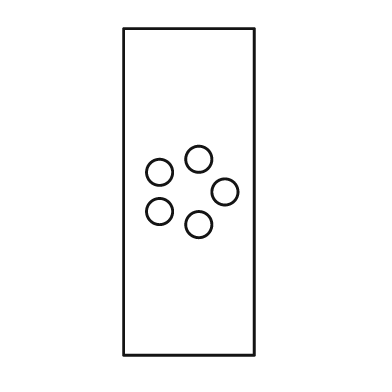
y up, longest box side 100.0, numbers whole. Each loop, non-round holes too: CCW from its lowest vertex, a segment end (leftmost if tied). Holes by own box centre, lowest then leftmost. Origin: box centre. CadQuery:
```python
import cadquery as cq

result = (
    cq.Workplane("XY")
    .moveTo(-20.0, -50.0)
    .lineTo(20.0, -50.0)
    .lineTo(20.0, 50.0)
    .lineTo(-20.0, 50.0)
    .close()
    .moveTo(3.0, -10.0)
    .circle(4.0)
    .moveTo(-9.0, -6.0)
    .circle(4.0)
    .moveTo(11.0, 0.0)
    .circle(4.0)
    .moveTo(-9.0, 6.0)
    .circle(4.0)
    .moveTo(3.0, 10.0)
    .circle(4.0)
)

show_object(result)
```